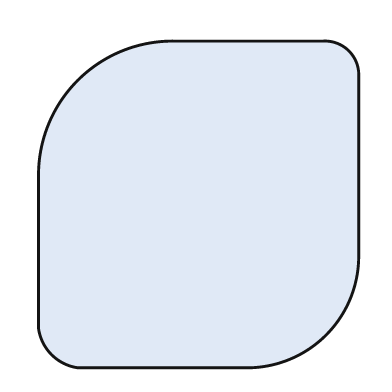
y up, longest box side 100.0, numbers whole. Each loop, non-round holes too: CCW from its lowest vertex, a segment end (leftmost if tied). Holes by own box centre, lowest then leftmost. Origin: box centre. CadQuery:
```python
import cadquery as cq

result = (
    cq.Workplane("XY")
    .moveTo(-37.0, -50.0)
    .lineTo(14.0, -50.0)
    .threePointArc((39.0, -40.0), (49.0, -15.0))
    .lineTo(49.0, 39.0)
    .threePointArc((46.0, 47.0), (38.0, 50.0))
    .lineTo(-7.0, 50.0)
    .threePointArc((-37.0, 38.0), (-49.0, 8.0))
    .lineTo(-49.0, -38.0)
    .threePointArc((-45.0, -46.0), (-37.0, -50.0))
    .close()
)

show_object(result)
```